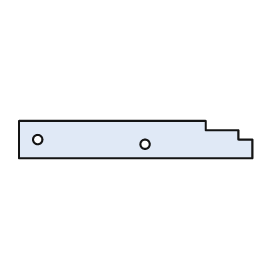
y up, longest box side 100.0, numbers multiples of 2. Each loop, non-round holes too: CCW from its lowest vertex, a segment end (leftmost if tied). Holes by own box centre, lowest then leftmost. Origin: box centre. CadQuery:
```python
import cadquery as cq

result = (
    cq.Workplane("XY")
    .moveTo(-50.0, -8.0)
    .lineTo(50.0, -8.0)
    .lineTo(50.0, 0.0)
    .lineTo(44.0, 0.0)
    .lineTo(44.0, 4.0)
    .lineTo(30.0, 4.0)
    .lineTo(30.0, 8.0)
    .lineTo(-50.0, 8.0)
    .close()
    .moveTo(4.0, -2.0)
    .circle(2.0)
    .moveTo(-42.0, 0.0)
    .circle(2.0)
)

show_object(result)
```